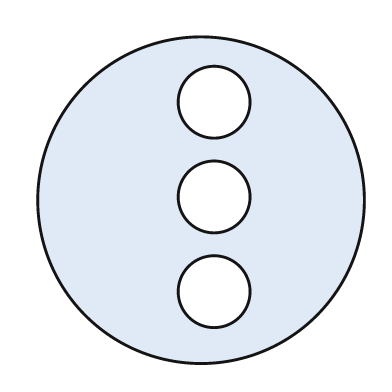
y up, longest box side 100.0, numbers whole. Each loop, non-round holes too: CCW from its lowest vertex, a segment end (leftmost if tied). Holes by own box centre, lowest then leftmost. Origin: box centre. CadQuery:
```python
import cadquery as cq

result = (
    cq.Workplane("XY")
    .moveTo(0.0, 0.0)
    .circle(50.0)
    .moveTo(4.0, -28.0)
    .circle(11.0)
    .moveTo(4.0, 1.0)
    .circle(11.0)
    .moveTo(4.0, 30.0)
    .circle(11.0)
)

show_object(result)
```